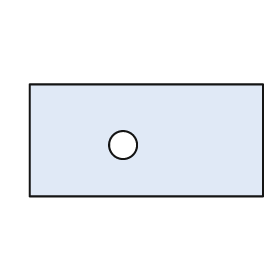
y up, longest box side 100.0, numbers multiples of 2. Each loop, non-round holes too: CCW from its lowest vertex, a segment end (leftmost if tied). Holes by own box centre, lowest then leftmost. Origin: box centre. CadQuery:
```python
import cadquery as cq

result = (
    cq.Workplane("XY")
    .moveTo(-50.0, -24.0)
    .lineTo(50.0, -24.0)
    .lineTo(50.0, 24.0)
    .lineTo(-50.0, 24.0)
    .close()
    .moveTo(-10.0, -2.0)
    .circle(6.0)
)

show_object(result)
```